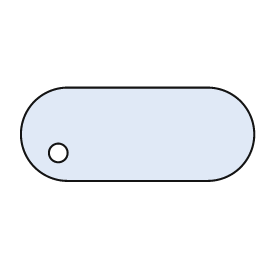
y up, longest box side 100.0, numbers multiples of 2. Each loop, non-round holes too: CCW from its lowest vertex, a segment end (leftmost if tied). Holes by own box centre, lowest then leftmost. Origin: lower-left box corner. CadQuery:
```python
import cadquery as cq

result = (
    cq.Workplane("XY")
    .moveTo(20.0, 0.0)
    .lineTo(80.0, 0.0)
    .threePointArc((100.0, 20.0), (80.0, 40.0))
    .lineTo(20.0, 40.0)
    .threePointArc((0.0, 20.0), (20.0, 0.0))
    .close()
    .moveTo(16.0, 12.0)
    .circle(4.0)
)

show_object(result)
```